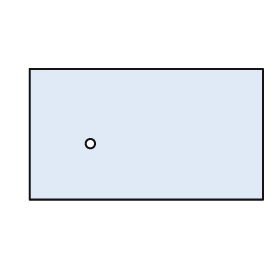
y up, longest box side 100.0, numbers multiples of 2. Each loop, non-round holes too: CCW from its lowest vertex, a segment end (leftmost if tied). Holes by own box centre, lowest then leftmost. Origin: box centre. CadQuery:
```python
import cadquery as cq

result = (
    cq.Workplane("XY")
    .moveTo(-50.0, -28.0)
    .lineTo(50.0, -28.0)
    .lineTo(50.0, 28.0)
    .lineTo(-50.0, 28.0)
    .close()
    .moveTo(-24.0, -4.0)
    .circle(2.0)
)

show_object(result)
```